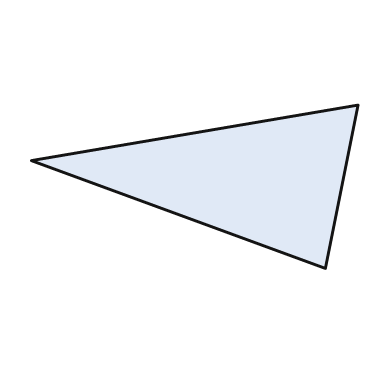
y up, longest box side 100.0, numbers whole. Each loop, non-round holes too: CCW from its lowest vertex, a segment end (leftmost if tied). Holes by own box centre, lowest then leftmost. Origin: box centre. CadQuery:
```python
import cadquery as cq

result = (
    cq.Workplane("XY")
    .moveTo(40.0, -25.0)
    .lineTo(50.0, 25.0)
    .lineTo(-50.0, 8.0)
    .close()
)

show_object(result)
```